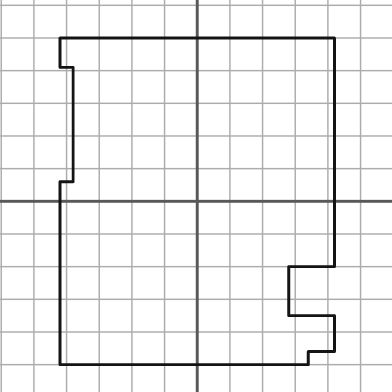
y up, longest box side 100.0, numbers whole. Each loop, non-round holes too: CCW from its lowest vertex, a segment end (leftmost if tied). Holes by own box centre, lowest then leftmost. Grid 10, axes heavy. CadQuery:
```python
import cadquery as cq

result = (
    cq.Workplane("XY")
    .moveTo(-42.0, -50.0)
    .lineTo(34.0, -50.0)
    .lineTo(34.0, -46.0)
    .lineTo(42.0, -46.0)
    .lineTo(42.0, -35.0)
    .lineTo(28.0, -35.0)
    .lineTo(28.0, -20.0)
    .lineTo(42.0, -20.0)
    .lineTo(42.0, 50.0)
    .lineTo(-42.0, 50.0)
    .lineTo(-42.0, 41.0)
    .lineTo(-38.0, 41.0)
    .lineTo(-38.0, 6.0)
    .lineTo(-42.0, 6.0)
    .close()
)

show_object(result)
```